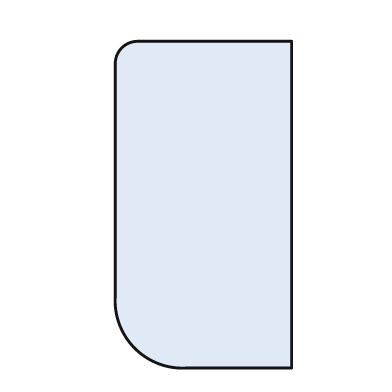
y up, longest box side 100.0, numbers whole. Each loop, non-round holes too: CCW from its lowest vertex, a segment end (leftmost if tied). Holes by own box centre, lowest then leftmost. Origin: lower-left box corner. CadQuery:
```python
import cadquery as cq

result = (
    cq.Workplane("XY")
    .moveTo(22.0, 0.0)
    .lineTo(54.0, 0.0)
    .lineTo(54.0, 100.0)
    .lineTo(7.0, 100.0)
    .threePointArc((2.0, 98.0), (0.0, 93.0))
    .lineTo(0.0, 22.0)
    .threePointArc((6.0, 6.0), (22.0, 0.0))
    .close()
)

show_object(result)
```